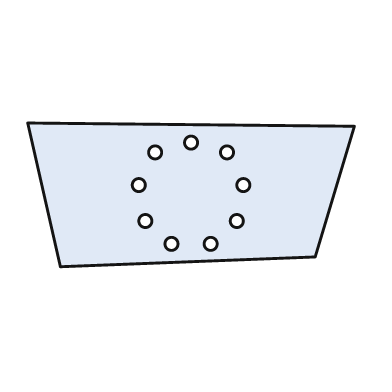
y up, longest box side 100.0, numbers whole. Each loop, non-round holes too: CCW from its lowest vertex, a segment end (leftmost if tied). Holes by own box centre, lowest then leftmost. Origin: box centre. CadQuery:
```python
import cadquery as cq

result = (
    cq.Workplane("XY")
    .moveTo(-40.0, -22.0)
    .lineTo(38.0, -19.0)
    .lineTo(50.0, 21.0)
    .lineTo(-50.0, 22.0)
    .close()
    .moveTo(-6.0, -15.0)
    .circle(2.0)
    .moveTo(6.0, -15.0)
    .circle(2.0)
    .moveTo(-14.0, -8.0)
    .circle(2.0)
    .moveTo(14.0, -8.0)
    .circle(2.0)
    .moveTo(-16.0, 3.0)
    .circle(2.0)
    .moveTo(16.0, 3.0)
    .circle(2.0)
    .moveTo(-11.0, 13.0)
    .circle(2.0)
    .moveTo(11.0, 13.0)
    .circle(2.0)
    .moveTo(0.0, 16.0)
    .circle(2.0)
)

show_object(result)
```